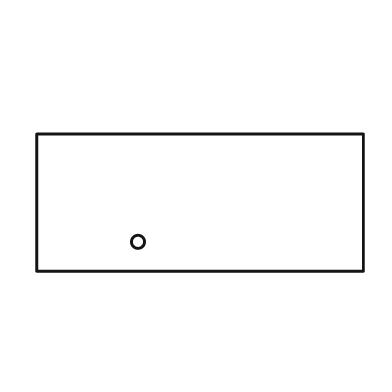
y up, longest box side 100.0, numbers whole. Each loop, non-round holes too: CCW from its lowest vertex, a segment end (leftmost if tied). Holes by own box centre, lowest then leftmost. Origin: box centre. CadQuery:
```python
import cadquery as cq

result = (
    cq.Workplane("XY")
    .moveTo(-50.0, -21.0)
    .lineTo(50.0, -21.0)
    .lineTo(50.0, 21.0)
    .lineTo(-50.0, 21.0)
    .close()
    .moveTo(-19.0, -12.0)
    .circle(2.0)
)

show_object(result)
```